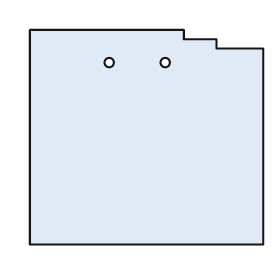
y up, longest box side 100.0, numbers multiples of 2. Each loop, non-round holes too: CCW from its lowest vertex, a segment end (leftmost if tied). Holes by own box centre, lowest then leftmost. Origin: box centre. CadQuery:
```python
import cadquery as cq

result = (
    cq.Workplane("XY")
    .moveTo(-50.0, -46.0)
    .lineTo(50.0, -46.0)
    .lineTo(50.0, 38.0)
    .lineTo(30.0, 38.0)
    .lineTo(30.0, 42.0)
    .lineTo(16.0, 42.0)
    .lineTo(16.0, 46.0)
    .lineTo(-50.0, 46.0)
    .close()
    .moveTo(-16.0, 32.0)
    .circle(2.0)
    .moveTo(8.0, 32.0)
    .circle(2.0)
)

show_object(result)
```